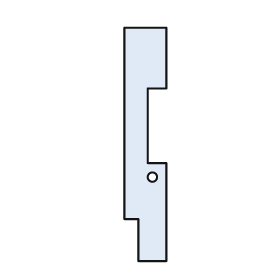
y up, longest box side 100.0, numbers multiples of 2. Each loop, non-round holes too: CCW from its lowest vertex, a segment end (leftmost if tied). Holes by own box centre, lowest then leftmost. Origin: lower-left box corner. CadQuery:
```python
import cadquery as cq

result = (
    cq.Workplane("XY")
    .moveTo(6.0, 0.0)
    .lineTo(18.0, 0.0)
    .lineTo(18.0, 42.0)
    .lineTo(10.0, 42.0)
    .lineTo(10.0, 74.0)
    .lineTo(18.0, 74.0)
    .lineTo(18.0, 100.0)
    .lineTo(0.0, 100.0)
    .lineTo(0.0, 18.0)
    .lineTo(6.0, 18.0)
    .close()
    .moveTo(12.0, 36.0)
    .circle(2.0)
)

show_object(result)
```